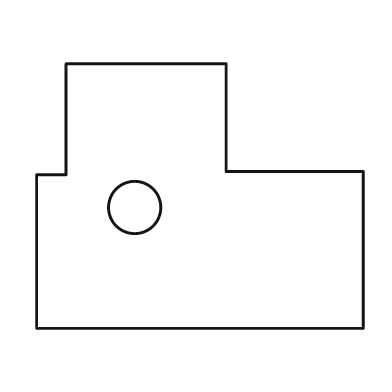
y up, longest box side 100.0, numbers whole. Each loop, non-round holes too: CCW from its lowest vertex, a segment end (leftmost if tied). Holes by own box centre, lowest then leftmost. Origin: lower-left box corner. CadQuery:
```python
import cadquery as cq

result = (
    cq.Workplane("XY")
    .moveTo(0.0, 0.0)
    .lineTo(100.0, 0.0)
    .lineTo(100.0, 48.0)
    .lineTo(58.0, 48.0)
    .lineTo(58.0, 81.0)
    .lineTo(9.0, 81.0)
    .lineTo(9.0, 47.0)
    .lineTo(0.0, 47.0)
    .close()
    .moveTo(30.0, 37.0)
    .circle(8.0)
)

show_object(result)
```